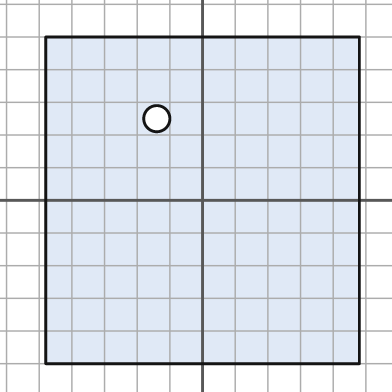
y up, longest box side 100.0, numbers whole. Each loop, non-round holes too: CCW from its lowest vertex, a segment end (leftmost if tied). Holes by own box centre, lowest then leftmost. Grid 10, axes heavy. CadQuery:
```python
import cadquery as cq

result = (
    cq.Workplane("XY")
    .moveTo(-48.0, -50.0)
    .lineTo(48.0, -50.0)
    .lineTo(48.0, 50.0)
    .lineTo(-48.0, 50.0)
    .close()
    .moveTo(-14.0, 25.0)
    .circle(4.0)
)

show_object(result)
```